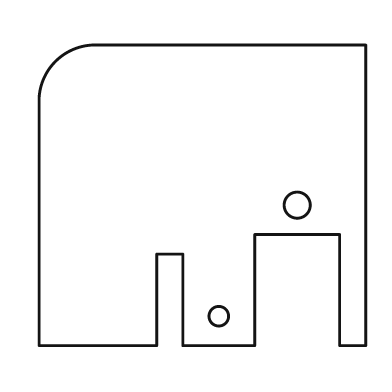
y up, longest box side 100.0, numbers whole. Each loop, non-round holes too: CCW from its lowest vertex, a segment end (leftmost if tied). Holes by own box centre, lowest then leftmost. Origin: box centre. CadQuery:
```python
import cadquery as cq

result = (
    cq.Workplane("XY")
    .moveTo(-50.0, -46.0)
    .lineTo(-14.0, -46.0)
    .lineTo(-14.0, -18.0)
    .lineTo(-6.0, -18.0)
    .lineTo(-6.0, -46.0)
    .lineTo(16.0, -46.0)
    .lineTo(16.0, -12.0)
    .lineTo(42.0, -12.0)
    .lineTo(42.0, -46.0)
    .lineTo(50.0, -46.0)
    .lineTo(50.0, 46.0)
    .lineTo(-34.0, 46.0)
    .threePointArc((-45.0, 41.0), (-50.0, 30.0))
    .close()
    .moveTo(5.0, -37.0)
    .circle(3.0)
    .moveTo(29.0, -3.0)
    .circle(4.0)
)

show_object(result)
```